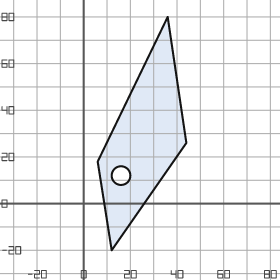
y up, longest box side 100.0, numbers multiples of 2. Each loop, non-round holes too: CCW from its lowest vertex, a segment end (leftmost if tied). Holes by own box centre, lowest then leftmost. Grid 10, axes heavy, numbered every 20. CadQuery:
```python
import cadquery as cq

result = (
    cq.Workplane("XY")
    .moveTo(12.0, -20.0)
    .lineTo(44.0, 26.0)
    .lineTo(36.0, 80.0)
    .lineTo(6.0, 18.0)
    .close()
    .moveTo(16.0, 12.0)
    .circle(4.0)
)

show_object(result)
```